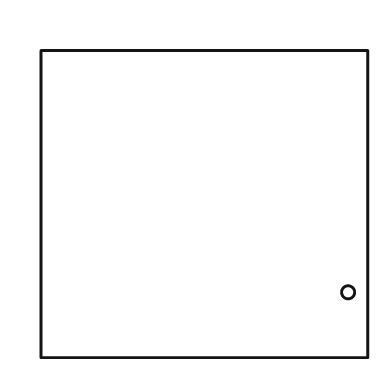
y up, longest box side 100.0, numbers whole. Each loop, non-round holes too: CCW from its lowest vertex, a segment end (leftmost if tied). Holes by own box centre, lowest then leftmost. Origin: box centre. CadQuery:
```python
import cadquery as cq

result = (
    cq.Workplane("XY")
    .moveTo(-50.0, -47.0)
    .lineTo(50.0, -47.0)
    .lineTo(50.0, 47.0)
    .lineTo(-50.0, 47.0)
    .close()
    .moveTo(44.0, -27.0)
    .circle(2.0)
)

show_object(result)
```